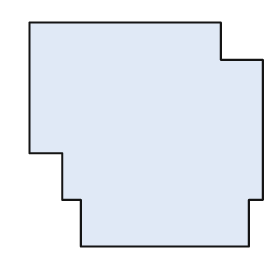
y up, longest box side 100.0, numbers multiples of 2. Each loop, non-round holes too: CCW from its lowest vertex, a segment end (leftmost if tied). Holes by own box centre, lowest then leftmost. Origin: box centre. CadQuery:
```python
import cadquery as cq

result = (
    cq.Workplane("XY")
    .moveTo(-28.0, -48.0)
    .lineTo(44.0, -48.0)
    .lineTo(44.0, -28.0)
    .lineTo(50.0, -28.0)
    .lineTo(50.0, 32.0)
    .lineTo(32.0, 32.0)
    .lineTo(32.0, 48.0)
    .lineTo(-50.0, 48.0)
    .lineTo(-50.0, -8.0)
    .lineTo(-36.0, -8.0)
    .lineTo(-36.0, -28.0)
    .lineTo(-28.0, -28.0)
    .close()
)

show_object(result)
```